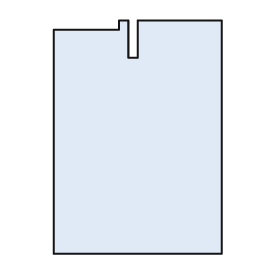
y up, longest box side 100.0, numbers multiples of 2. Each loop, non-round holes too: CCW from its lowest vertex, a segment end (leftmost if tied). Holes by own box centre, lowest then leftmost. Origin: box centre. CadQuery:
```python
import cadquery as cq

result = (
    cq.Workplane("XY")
    .moveTo(-36.0, -50.0)
    .lineTo(36.0, -50.0)
    .lineTo(36.0, 50.0)
    .lineTo(0.0, 50.0)
    .lineTo(0.0, 34.0)
    .lineTo(-4.0, 34.0)
    .lineTo(-4.0, 50.0)
    .lineTo(-8.0, 50.0)
    .lineTo(-8.0, 46.0)
    .lineTo(-36.0, 46.0)
    .close()
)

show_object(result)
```